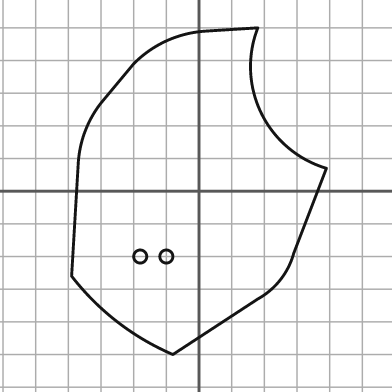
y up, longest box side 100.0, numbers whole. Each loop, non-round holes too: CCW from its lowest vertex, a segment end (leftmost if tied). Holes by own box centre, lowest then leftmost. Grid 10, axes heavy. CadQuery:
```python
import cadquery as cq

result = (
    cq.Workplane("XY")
    .moveTo(-8.0, -50.0)
    .lineTo(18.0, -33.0)
    .threePointArc((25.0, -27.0), (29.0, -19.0))
    .lineTo(39.0, 7.0)
    .threePointArc((19.0, 24.0), (18.0, 50.0))
    .lineTo(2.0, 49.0)
    .threePointArc((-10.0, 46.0), (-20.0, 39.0))
    .lineTo(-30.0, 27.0)
    .threePointArc((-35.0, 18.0), (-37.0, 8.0))
    .lineTo(-39.0, -26.0)
    .threePointArc((-25.0, -40.0), (-8.0, -50.0))
    .close()
    .moveTo(-18.0, -20.0)
    .circle(2.0)
    .moveTo(-10.0, -20.0)
    .circle(2.0)
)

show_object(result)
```